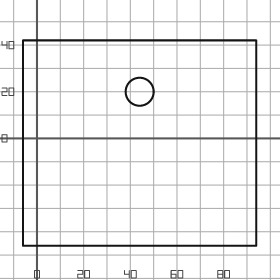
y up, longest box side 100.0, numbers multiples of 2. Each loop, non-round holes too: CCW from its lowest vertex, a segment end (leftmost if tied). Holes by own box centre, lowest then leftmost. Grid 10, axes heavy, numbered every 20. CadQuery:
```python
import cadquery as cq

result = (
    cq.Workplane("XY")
    .moveTo(-6.0, -46.0)
    .lineTo(94.0, -46.0)
    .lineTo(94.0, 42.0)
    .lineTo(-6.0, 42.0)
    .close()
    .moveTo(44.0, 20.0)
    .circle(6.0)
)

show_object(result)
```